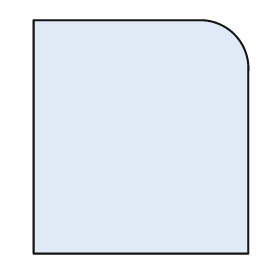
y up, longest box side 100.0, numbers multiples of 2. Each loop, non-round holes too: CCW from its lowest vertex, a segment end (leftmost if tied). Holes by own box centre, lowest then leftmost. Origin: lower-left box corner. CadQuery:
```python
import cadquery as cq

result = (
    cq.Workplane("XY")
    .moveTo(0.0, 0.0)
    .lineTo(92.0, 0.0)
    .lineTo(92.0, 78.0)
    .threePointArc((86.0, 94.0), (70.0, 100.0))
    .lineTo(0.0, 100.0)
    .close()
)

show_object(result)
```